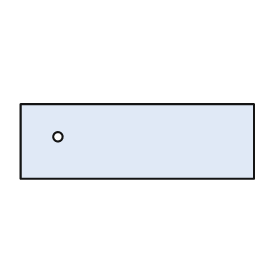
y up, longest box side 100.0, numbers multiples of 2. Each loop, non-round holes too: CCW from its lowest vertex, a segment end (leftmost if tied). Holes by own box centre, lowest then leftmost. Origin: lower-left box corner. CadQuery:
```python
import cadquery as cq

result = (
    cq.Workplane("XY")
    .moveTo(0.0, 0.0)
    .lineTo(100.0, 0.0)
    .lineTo(100.0, 32.0)
    .lineTo(0.0, 32.0)
    .close()
    .moveTo(16.0, 18.0)
    .circle(2.0)
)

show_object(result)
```